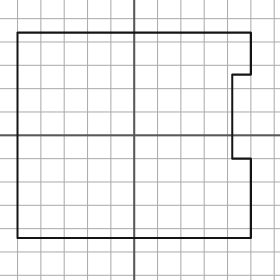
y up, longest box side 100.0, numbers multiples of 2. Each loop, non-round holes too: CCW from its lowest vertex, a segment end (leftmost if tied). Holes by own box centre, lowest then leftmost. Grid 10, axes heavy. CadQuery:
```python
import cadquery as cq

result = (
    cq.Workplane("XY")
    .moveTo(-50.0, -44.0)
    .lineTo(50.0, -44.0)
    .lineTo(50.0, -10.0)
    .lineTo(42.0, -10.0)
    .lineTo(42.0, 26.0)
    .lineTo(50.0, 26.0)
    .lineTo(50.0, 44.0)
    .lineTo(-50.0, 44.0)
    .close()
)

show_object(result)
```